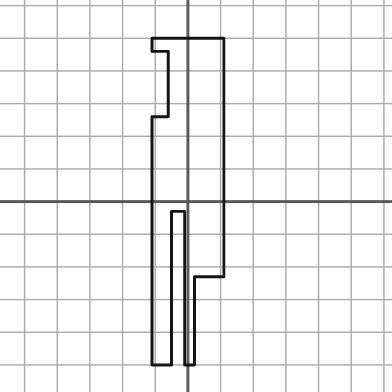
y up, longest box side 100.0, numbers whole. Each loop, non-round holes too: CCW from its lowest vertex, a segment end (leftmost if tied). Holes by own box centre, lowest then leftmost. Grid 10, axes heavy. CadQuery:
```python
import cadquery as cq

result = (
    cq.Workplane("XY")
    .moveTo(-11.0, -50.0)
    .lineTo(-5.0, -50.0)
    .lineTo(-5.0, -3.0)
    .lineTo(-1.0, -3.0)
    .lineTo(-1.0, -50.0)
    .lineTo(2.0, -50.0)
    .lineTo(2.0, -23.0)
    .lineTo(11.0, -23.0)
    .lineTo(11.0, 50.0)
    .lineTo(-11.0, 50.0)
    .lineTo(-11.0, 46.0)
    .lineTo(-6.0, 46.0)
    .lineTo(-6.0, 26.0)
    .lineTo(-11.0, 26.0)
    .close()
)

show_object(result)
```